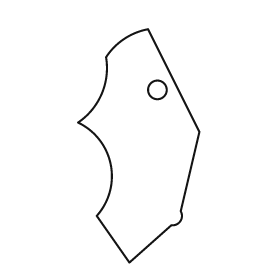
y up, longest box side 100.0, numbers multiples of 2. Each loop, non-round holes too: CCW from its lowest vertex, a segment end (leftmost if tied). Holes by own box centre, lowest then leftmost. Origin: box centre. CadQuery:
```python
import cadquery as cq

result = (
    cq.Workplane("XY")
    .moveTo(-4.0, -50.0)
    .lineTo(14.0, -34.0)
    .threePointArc((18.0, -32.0), (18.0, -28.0))
    .lineTo(26.0, 6.0)
    .lineTo(4.0, 50.0)
    .threePointArc((-6.0, 46.0), (-14.0, 38.0))
    .threePointArc((-16.0, 22.0), (-26.0, 10.0))
    .threePointArc((-12.0, -8.0), (-18.0, -30.0))
    .close()
    .moveTo(8.0, 24.0)
    .circle(4.0)
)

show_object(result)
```